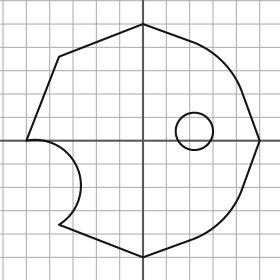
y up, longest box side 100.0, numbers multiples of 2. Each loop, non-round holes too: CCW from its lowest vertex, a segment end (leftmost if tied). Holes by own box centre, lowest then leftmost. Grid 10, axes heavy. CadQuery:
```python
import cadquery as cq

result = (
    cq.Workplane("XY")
    .moveTo(0.0, -50.0)
    .lineTo(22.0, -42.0)
    .threePointArc((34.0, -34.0), (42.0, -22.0))
    .lineTo(50.0, 0.0)
    .lineTo(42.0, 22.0)
    .threePointArc((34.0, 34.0), (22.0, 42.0))
    .lineTo(0.0, 50.0)
    .lineTo(-36.0, 36.0)
    .lineTo(-50.0, 0.0)
    .threePointArc((-28.0, -12.0), (-36.0, -36.0))
    .close()
    .moveTo(22.0, 4.0)
    .circle(8.0)
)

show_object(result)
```